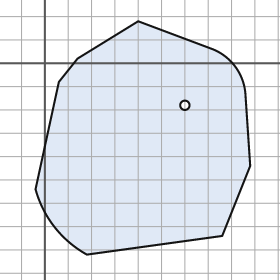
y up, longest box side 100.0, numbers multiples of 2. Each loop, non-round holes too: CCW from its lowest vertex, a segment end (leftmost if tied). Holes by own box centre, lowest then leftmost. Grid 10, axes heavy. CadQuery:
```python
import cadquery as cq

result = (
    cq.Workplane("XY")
    .moveTo(18.0, -82.0)
    .lineTo(76.0, -74.0)
    .lineTo(88.0, -44.0)
    .lineTo(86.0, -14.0)
    .threePointArc((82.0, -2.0), (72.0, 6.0))
    .lineTo(40.0, 18.0)
    .lineTo(14.0, 2.0)
    .lineTo(6.0, -8.0)
    .lineTo(-4.0, -54.0)
    .threePointArc((4.0, -70.0), (18.0, -82.0))
    .close()
    .moveTo(60.0, -18.0)
    .circle(2.0)
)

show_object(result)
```